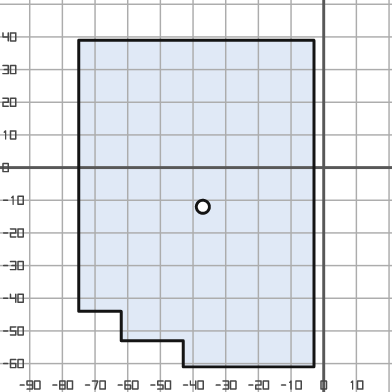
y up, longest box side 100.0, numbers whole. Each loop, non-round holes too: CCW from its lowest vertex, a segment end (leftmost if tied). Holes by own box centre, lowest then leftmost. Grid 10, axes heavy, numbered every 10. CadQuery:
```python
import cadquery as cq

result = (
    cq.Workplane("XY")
    .moveTo(-43.0, -61.0)
    .lineTo(-3.0, -61.0)
    .lineTo(-3.0, 39.0)
    .lineTo(-75.0, 39.0)
    .lineTo(-75.0, -44.0)
    .lineTo(-62.0, -44.0)
    .lineTo(-62.0, -53.0)
    .lineTo(-43.0, -53.0)
    .close()
    .moveTo(-37.0, -12.0)
    .circle(2.0)
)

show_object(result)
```